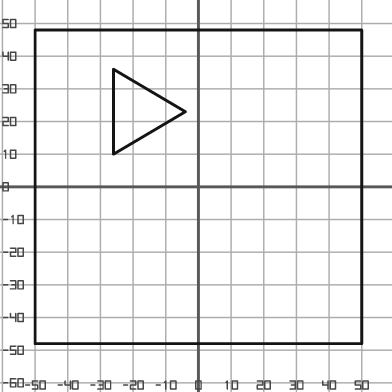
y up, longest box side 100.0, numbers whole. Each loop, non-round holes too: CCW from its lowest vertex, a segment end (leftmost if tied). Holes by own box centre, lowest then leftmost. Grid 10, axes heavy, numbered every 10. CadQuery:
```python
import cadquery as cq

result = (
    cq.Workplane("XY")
    .moveTo(-50.0, -48.0)
    .lineTo(50.0, -48.0)
    .lineTo(50.0, 48.0)
    .lineTo(-50.0, 48.0)
    .close()
    .moveTo(-26.0, 10.0)
    .lineTo(-4.0, 23.0)
    .lineTo(-26.0, 36.0)
    .close()
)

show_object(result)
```